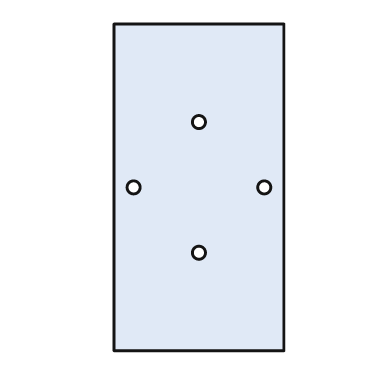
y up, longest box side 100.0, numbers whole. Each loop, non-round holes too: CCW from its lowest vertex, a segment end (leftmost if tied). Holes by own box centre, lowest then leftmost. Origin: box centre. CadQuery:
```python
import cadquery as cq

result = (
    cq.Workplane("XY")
    .moveTo(-26.0, -50.0)
    .lineTo(26.0, -50.0)
    .lineTo(26.0, 50.0)
    .lineTo(-26.0, 50.0)
    .close()
    .moveTo(0.0, -20.0)
    .circle(2.0)
    .moveTo(-20.0, 0.0)
    .circle(2.0)
    .moveTo(20.0, 0.0)
    .circle(2.0)
    .moveTo(0.0, 20.0)
    .circle(2.0)
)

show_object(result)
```